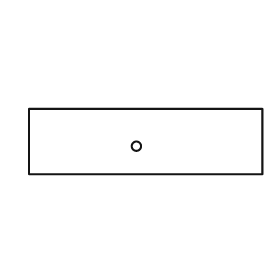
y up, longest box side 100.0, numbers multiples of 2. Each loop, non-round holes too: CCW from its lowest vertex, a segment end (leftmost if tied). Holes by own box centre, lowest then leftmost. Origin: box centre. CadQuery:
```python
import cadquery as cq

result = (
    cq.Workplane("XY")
    .moveTo(-50.0, -14.0)
    .lineTo(50.0, -14.0)
    .lineTo(50.0, 14.0)
    .lineTo(-50.0, 14.0)
    .close()
    .moveTo(-4.0, -2.0)
    .circle(2.0)
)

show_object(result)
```